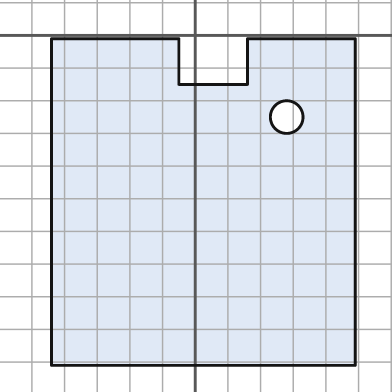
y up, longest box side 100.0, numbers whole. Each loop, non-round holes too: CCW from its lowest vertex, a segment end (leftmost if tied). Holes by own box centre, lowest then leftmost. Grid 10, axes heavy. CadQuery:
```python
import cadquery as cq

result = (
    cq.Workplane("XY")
    .moveTo(-44.0, -101.0)
    .lineTo(49.0, -101.0)
    .lineTo(49.0, -1.0)
    .lineTo(16.0, -1.0)
    .lineTo(16.0, -15.0)
    .lineTo(-5.0, -15.0)
    .lineTo(-5.0, -1.0)
    .lineTo(-44.0, -1.0)
    .close()
    .moveTo(28.0, -25.0)
    .circle(5.0)
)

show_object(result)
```